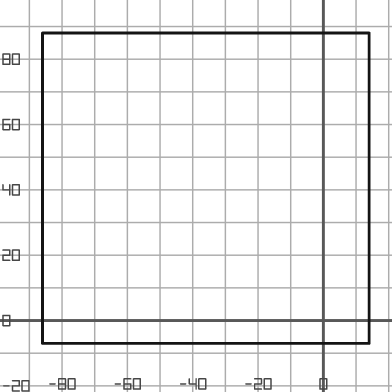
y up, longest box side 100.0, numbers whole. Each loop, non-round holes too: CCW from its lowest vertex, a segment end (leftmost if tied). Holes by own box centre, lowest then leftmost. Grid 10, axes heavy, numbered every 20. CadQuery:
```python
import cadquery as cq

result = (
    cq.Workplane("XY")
    .moveTo(-86.0, -7.0)
    .lineTo(14.0, -7.0)
    .lineTo(14.0, 88.0)
    .lineTo(-86.0, 88.0)
    .close()
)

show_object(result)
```